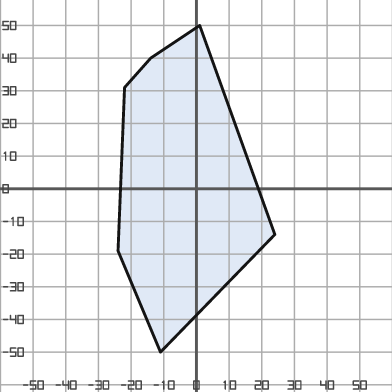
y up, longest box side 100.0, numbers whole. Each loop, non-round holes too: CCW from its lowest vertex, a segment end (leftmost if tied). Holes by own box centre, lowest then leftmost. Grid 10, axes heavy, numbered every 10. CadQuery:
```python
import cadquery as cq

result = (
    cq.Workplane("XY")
    .moveTo(-11.0, -50.0)
    .lineTo(24.0, -14.0)
    .lineTo(1.0, 50.0)
    .lineTo(-14.0, 40.0)
    .lineTo(-22.0, 31.0)
    .lineTo(-24.0, -19.0)
    .close()
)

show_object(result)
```